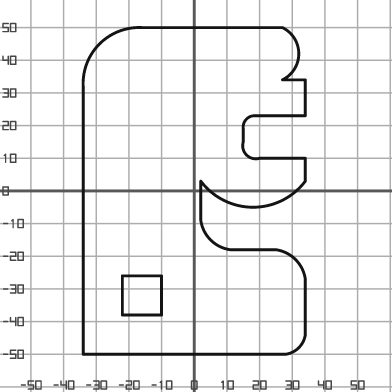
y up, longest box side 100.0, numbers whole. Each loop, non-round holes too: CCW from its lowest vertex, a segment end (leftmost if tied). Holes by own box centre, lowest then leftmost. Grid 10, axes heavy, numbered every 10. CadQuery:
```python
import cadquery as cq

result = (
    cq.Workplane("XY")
    .moveTo(-34.0, -50.0)
    .lineTo(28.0, -50.0)
    .threePointArc((32.0, -48.0), (34.0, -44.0))
    .lineTo(34.0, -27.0)
    .threePointArc((31.0, -21.0), (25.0, -18.0))
    .lineTo(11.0, -18.0)
    .threePointArc((5.0, -15.0), (2.0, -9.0))
    .lineTo(2.0, 3.0)
    .threePointArc((18.0, -5.0), (34.0, 3.0))
    .lineTo(34.0, 10.0)
    .lineTo(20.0, 10.0)
    .threePointArc((16.0, 11.0), (15.0, 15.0))
    .lineTo(15.0, 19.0)
    .threePointArc((16.0, 22.0), (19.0, 23.0))
    .lineTo(34.0, 23.0)
    .lineTo(34.0, 34.0)
    .lineTo(27.0, 34.0)
    .threePointArc((32.0, 42.0), (27.0, 50.0))
    .lineTo(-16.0, 50.0)
    .threePointArc((-29.0, 45.0), (-34.0, 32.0))
    .close()
    .moveTo(-22.0, -38.0)
    .lineTo(-10.0, -38.0)
    .lineTo(-10.0, -26.0)
    .lineTo(-22.0, -26.0)
    .close()
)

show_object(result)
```